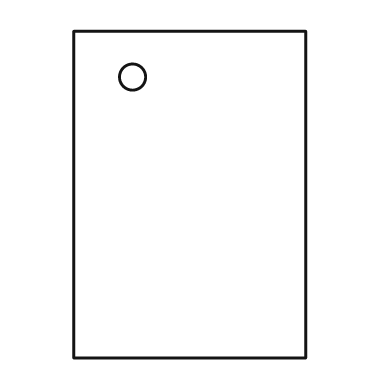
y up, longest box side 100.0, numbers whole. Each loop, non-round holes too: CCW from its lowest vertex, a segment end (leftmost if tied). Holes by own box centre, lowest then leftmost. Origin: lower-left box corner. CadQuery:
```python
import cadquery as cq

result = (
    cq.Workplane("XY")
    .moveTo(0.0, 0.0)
    .lineTo(71.0, 0.0)
    .lineTo(71.0, 100.0)
    .lineTo(0.0, 100.0)
    .close()
    .moveTo(18.0, 86.0)
    .circle(4.0)
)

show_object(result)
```